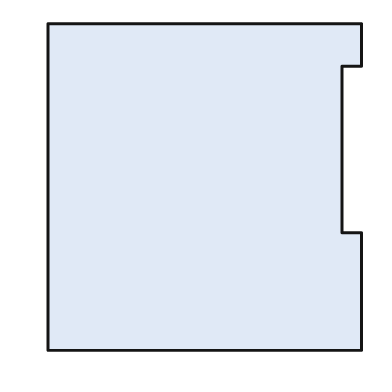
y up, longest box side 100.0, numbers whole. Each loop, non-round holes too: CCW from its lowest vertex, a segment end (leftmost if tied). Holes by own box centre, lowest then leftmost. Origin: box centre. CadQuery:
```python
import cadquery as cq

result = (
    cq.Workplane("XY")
    .moveTo(-48.0, -50.0)
    .lineTo(48.0, -50.0)
    .lineTo(48.0, -14.0)
    .lineTo(42.0, -14.0)
    .lineTo(42.0, 37.0)
    .lineTo(48.0, 37.0)
    .lineTo(48.0, 50.0)
    .lineTo(-48.0, 50.0)
    .close()
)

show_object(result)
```